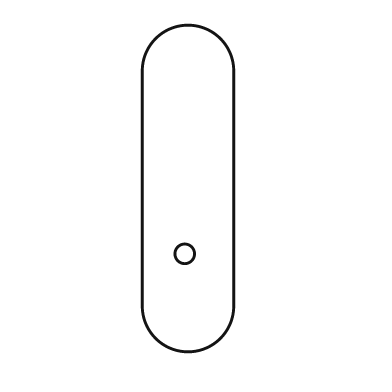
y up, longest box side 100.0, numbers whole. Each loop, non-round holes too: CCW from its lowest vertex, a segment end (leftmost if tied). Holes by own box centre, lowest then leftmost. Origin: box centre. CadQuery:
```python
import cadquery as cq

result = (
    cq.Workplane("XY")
    .moveTo(-14.0, -36.0)
    .threePointArc((0.0, -50.0), (14.0, -36.0))
    .lineTo(14.0, 36.0)
    .threePointArc((0.0, 50.0), (-14.0, 36.0))
    .close()
    .moveTo(-1.0, -20.0)
    .circle(3.0)
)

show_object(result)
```